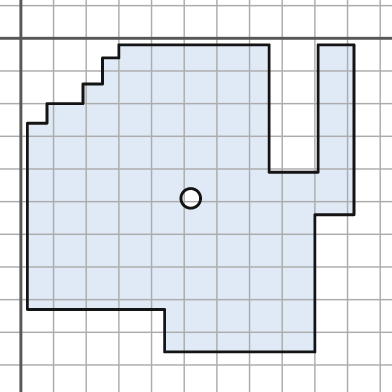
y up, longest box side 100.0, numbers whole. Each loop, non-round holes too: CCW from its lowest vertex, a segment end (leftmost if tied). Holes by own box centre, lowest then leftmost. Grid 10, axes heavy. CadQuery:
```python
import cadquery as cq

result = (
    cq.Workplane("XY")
    .moveTo(44.0, -96.0)
    .lineTo(90.0, -96.0)
    .lineTo(90.0, -54.0)
    .lineTo(102.0, -54.0)
    .lineTo(102.0, -2.0)
    .lineTo(91.0, -2.0)
    .lineTo(91.0, -41.0)
    .lineTo(76.0, -41.0)
    .lineTo(76.0, -2.0)
    .lineTo(30.0, -2.0)
    .lineTo(30.0, -6.0)
    .lineTo(25.0, -6.0)
    .lineTo(25.0, -14.0)
    .lineTo(19.0, -14.0)
    .lineTo(19.0, -20.0)
    .lineTo(8.0, -20.0)
    .lineTo(8.0, -26.0)
    .lineTo(2.0, -26.0)
    .lineTo(2.0, -83.0)
    .lineTo(44.0, -83.0)
    .close()
    .moveTo(52.0, -49.0)
    .circle(3.0)
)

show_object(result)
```